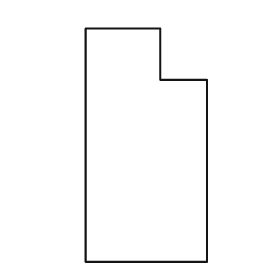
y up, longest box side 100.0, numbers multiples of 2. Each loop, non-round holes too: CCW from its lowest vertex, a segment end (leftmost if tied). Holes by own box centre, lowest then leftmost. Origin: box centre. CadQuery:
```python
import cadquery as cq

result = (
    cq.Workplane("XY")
    .moveTo(-26.0, -50.0)
    .lineTo(26.0, -50.0)
    .lineTo(26.0, 28.0)
    .lineTo(6.0, 28.0)
    .lineTo(6.0, 50.0)
    .lineTo(-26.0, 50.0)
    .close()
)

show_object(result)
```